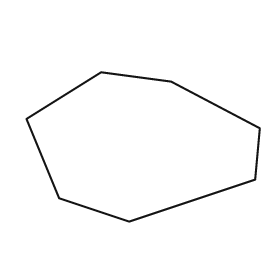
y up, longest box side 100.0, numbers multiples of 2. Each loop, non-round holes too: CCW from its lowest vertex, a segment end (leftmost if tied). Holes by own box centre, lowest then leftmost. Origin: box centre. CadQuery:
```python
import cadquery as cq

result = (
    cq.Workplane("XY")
    .moveTo(-6.0, -32.0)
    .lineTo(48.0, -14.0)
    .lineTo(50.0, 8.0)
    .lineTo(12.0, 28.0)
    .lineTo(-18.0, 32.0)
    .lineTo(-50.0, 12.0)
    .lineTo(-36.0, -22.0)
    .close()
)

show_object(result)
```